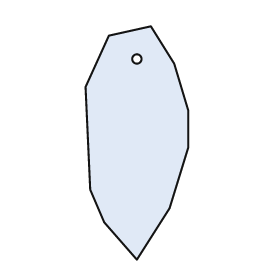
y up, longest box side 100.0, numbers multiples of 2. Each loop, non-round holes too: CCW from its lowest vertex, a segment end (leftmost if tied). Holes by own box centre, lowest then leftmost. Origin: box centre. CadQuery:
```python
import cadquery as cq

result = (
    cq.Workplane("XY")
    .moveTo(0.0, -50.0)
    .lineTo(14.0, -28.0)
    .lineTo(22.0, -2.0)
    .lineTo(22.0, 14.0)
    .lineTo(16.0, 34.0)
    .lineTo(6.0, 50.0)
    .lineTo(-12.0, 46.0)
    .lineTo(-22.0, 24.0)
    .lineTo(-20.0, -20.0)
    .lineTo(-14.0, -34.0)
    .close()
    .moveTo(0.0, 36.0)
    .circle(2.0)
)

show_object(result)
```